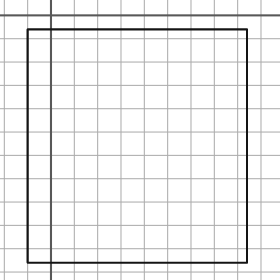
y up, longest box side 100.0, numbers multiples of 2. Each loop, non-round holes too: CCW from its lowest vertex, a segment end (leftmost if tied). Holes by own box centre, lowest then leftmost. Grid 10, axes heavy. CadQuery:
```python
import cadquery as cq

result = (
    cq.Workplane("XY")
    .moveTo(-10.0, -106.0)
    .lineTo(84.0, -106.0)
    .lineTo(84.0, -6.0)
    .lineTo(-10.0, -6.0)
    .close()
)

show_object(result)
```